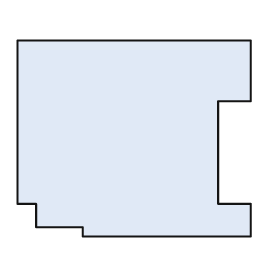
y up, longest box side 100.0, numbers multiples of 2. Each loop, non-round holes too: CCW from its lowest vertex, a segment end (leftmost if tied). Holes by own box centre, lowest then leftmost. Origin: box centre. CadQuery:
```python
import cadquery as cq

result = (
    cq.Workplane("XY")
    .moveTo(-22.0, -42.0)
    .lineTo(50.0, -42.0)
    .lineTo(50.0, -28.0)
    .lineTo(36.0, -28.0)
    .lineTo(36.0, 16.0)
    .lineTo(50.0, 16.0)
    .lineTo(50.0, 42.0)
    .lineTo(-50.0, 42.0)
    .lineTo(-50.0, -28.0)
    .lineTo(-42.0, -28.0)
    .lineTo(-42.0, -38.0)
    .lineTo(-22.0, -38.0)
    .close()
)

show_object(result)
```